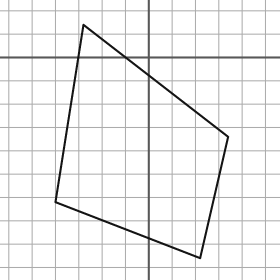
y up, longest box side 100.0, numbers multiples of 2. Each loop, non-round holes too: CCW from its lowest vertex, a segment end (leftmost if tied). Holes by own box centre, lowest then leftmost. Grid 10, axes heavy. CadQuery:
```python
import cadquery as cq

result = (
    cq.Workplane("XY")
    .moveTo(22.0, -86.0)
    .lineTo(34.0, -34.0)
    .lineTo(-28.0, 14.0)
    .lineTo(-40.0, -62.0)
    .close()
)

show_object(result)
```